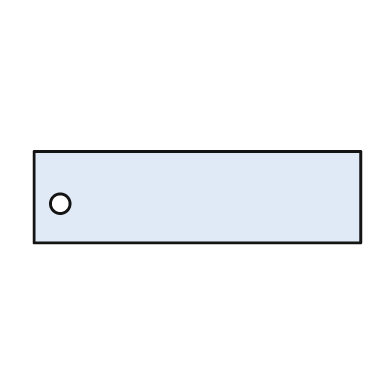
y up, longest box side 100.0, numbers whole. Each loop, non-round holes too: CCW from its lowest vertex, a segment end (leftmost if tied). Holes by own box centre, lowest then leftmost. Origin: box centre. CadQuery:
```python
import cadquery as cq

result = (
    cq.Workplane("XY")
    .moveTo(-50.0, -14.0)
    .lineTo(50.0, -14.0)
    .lineTo(50.0, 14.0)
    .lineTo(-50.0, 14.0)
    .close()
    .moveTo(-42.0, -2.0)
    .circle(3.0)
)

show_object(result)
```